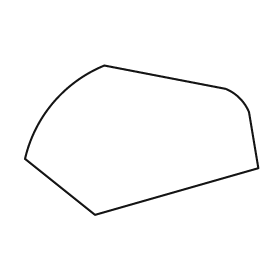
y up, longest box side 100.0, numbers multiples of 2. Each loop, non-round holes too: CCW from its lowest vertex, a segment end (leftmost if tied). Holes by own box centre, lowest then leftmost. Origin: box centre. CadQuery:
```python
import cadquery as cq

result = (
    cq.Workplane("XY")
    .moveTo(-20.0, -32.0)
    .lineTo(50.0, -12.0)
    .lineTo(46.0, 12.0)
    .threePointArc((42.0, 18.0), (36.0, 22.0))
    .lineTo(-16.0, 32.0)
    .threePointArc((-38.0, 16.0), (-50.0, -8.0))
    .close()
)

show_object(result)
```